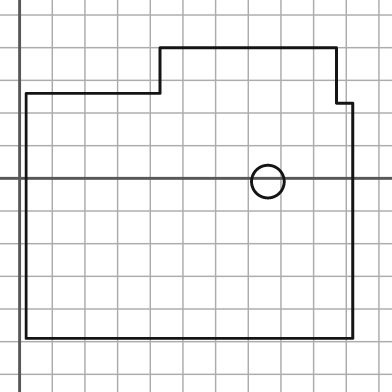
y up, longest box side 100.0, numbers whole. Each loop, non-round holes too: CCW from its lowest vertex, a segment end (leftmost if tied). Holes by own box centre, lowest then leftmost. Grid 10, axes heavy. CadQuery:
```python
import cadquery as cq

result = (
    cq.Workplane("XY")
    .moveTo(2.0, -49.0)
    .lineTo(102.0, -49.0)
    .lineTo(102.0, 23.0)
    .lineTo(97.0, 23.0)
    .lineTo(97.0, 40.0)
    .lineTo(43.0, 40.0)
    .lineTo(43.0, 26.0)
    .lineTo(2.0, 26.0)
    .close()
    .moveTo(76.0, -1.0)
    .circle(5.0)
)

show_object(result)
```